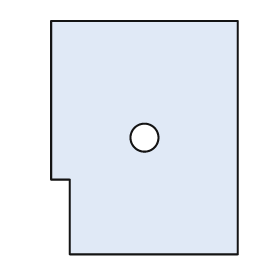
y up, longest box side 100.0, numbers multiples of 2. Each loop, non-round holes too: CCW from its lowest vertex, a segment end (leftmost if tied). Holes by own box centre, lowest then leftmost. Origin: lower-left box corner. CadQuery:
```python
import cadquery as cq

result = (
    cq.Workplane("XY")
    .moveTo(8.0, 0.0)
    .lineTo(80.0, 0.0)
    .lineTo(80.0, 100.0)
    .lineTo(0.0, 100.0)
    .lineTo(0.0, 32.0)
    .lineTo(8.0, 32.0)
    .close()
    .moveTo(40.0, 50.0)
    .circle(6.0)
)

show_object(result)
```